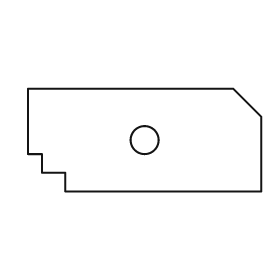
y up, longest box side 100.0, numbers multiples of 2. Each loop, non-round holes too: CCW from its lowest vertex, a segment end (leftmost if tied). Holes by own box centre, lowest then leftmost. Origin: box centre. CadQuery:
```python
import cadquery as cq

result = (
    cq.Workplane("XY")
    .moveTo(-34.0, -22.0)
    .lineTo(50.0, -22.0)
    .lineTo(50.0, 10.0)
    .lineTo(38.0, 22.0)
    .lineTo(-50.0, 22.0)
    .lineTo(-50.0, -6.0)
    .lineTo(-44.0, -6.0)
    .lineTo(-44.0, -14.0)
    .lineTo(-34.0, -14.0)
    .close()
    .moveTo(0.0, 0.0)
    .circle(6.0)
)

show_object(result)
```